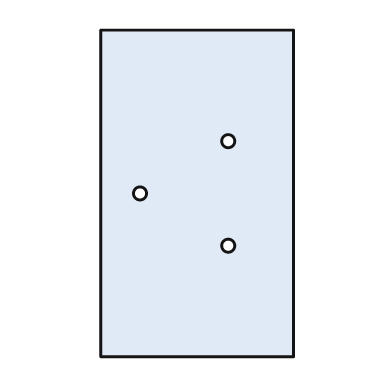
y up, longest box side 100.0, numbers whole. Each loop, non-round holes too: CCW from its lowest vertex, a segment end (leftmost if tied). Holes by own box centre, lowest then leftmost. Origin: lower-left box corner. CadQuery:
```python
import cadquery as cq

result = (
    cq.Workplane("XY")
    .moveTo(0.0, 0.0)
    .lineTo(59.0, 0.0)
    .lineTo(59.0, 100.0)
    .lineTo(0.0, 100.0)
    .close()
    .moveTo(39.0, 34.0)
    .circle(2.0)
    .moveTo(12.0, 50.0)
    .circle(2.0)
    .moveTo(39.0, 66.0)
    .circle(2.0)
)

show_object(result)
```